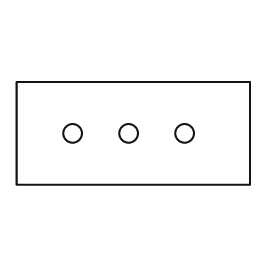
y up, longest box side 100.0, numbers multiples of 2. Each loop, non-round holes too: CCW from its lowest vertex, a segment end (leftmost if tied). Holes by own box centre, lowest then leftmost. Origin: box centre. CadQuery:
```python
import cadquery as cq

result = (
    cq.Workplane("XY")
    .moveTo(-50.0, -22.0)
    .lineTo(50.0, -22.0)
    .lineTo(50.0, 22.0)
    .lineTo(-50.0, 22.0)
    .close()
    .moveTo(-26.0, 0.0)
    .circle(4.0)
    .moveTo(-2.0, 0.0)
    .circle(4.0)
    .moveTo(22.0, 0.0)
    .circle(4.0)
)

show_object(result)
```